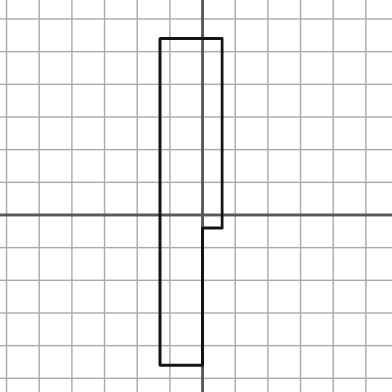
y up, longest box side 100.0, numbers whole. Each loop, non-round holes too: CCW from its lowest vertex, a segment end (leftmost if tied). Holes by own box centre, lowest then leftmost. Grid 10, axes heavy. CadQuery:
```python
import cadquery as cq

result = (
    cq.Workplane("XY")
    .moveTo(-13.0, -46.0)
    .lineTo(0.0, -46.0)
    .lineTo(0.0, -4.0)
    .lineTo(6.0, -4.0)
    .lineTo(6.0, 54.0)
    .lineTo(-13.0, 54.0)
    .close()
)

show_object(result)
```